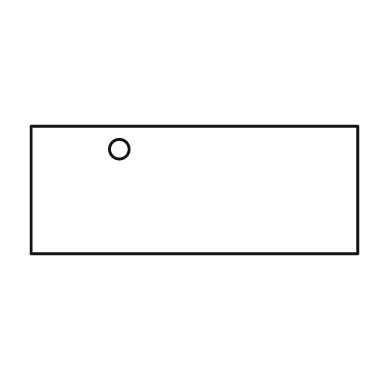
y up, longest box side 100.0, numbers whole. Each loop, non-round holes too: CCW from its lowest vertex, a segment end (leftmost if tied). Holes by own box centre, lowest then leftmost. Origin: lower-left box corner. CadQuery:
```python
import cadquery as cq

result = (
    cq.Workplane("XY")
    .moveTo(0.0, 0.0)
    .lineTo(100.0, 0.0)
    .lineTo(100.0, 39.0)
    .lineTo(0.0, 39.0)
    .close()
    .moveTo(27.0, 32.0)
    .circle(3.0)
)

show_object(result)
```